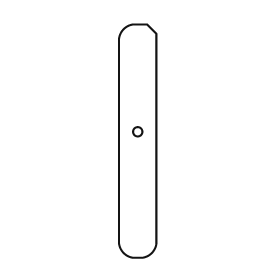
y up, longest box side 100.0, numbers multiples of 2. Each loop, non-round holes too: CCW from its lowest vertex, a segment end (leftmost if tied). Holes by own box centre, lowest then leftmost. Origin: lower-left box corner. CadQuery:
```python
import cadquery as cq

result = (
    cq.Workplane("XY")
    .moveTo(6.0, 0.0)
    .lineTo(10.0, 0.0)
    .threePointArc((14.0, 2.0), (16.0, 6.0))
    .lineTo(16.0, 96.0)
    .lineTo(12.0, 100.0)
    .lineTo(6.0, 100.0)
    .threePointArc((2.0, 98.0), (0.0, 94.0))
    .lineTo(0.0, 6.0)
    .threePointArc((2.0, 2.0), (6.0, 0.0))
    .close()
    .moveTo(8.0, 54.0)
    .circle(2.0)
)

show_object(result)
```